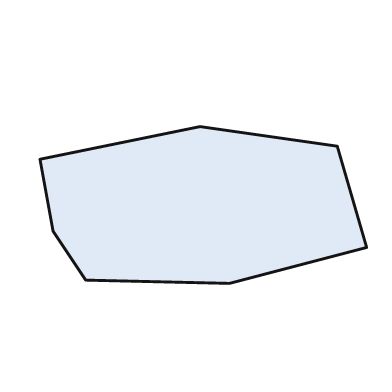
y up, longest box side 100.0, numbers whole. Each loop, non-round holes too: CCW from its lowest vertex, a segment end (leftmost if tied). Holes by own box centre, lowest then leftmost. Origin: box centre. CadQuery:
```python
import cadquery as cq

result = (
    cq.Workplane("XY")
    .moveTo(8.0, -24.0)
    .lineTo(50.0, -13.0)
    .lineTo(41.0, 18.0)
    .lineTo(-1.0, 24.0)
    .lineTo(-50.0, 14.0)
    .lineTo(-46.0, -8.0)
    .lineTo(-36.0, -23.0)
    .close()
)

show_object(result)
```